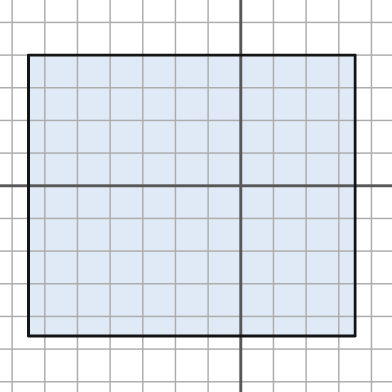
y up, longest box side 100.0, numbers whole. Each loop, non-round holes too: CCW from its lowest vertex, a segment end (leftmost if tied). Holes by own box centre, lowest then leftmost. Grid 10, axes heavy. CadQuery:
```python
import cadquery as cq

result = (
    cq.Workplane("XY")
    .moveTo(-65.0, -46.0)
    .lineTo(35.0, -46.0)
    .lineTo(35.0, 40.0)
    .lineTo(-65.0, 40.0)
    .close()
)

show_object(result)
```